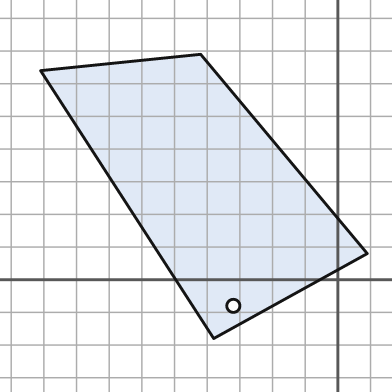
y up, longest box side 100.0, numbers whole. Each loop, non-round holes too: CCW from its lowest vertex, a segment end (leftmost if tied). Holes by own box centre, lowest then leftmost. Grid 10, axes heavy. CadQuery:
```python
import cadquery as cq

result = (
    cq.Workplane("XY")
    .moveTo(-38.0, -18.0)
    .lineTo(9.0, 8.0)
    .lineTo(-42.0, 69.0)
    .lineTo(-91.0, 64.0)
    .close()
    .moveTo(-32.0, -8.0)
    .circle(2.0)
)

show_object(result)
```